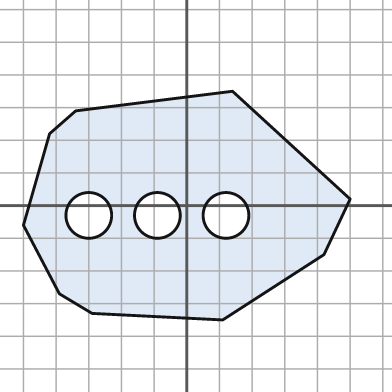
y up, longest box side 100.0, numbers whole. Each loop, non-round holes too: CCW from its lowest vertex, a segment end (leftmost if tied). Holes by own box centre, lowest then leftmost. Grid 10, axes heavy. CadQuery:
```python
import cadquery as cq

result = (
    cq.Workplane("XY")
    .moveTo(11.0, -35.0)
    .lineTo(42.0, -15.0)
    .lineTo(50.0, 2.0)
    .lineTo(14.0, 35.0)
    .lineTo(-34.0, 29.0)
    .lineTo(-42.0, 22.0)
    .lineTo(-50.0, -6.0)
    .lineTo(-39.0, -27.0)
    .lineTo(-29.0, -33.0)
    .close()
    .moveTo(-30.0, -3.0)
    .circle(7.0)
    .moveTo(-9.0, -3.0)
    .circle(7.0)
    .moveTo(12.0, -3.0)
    .circle(7.0)
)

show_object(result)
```